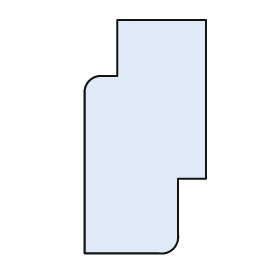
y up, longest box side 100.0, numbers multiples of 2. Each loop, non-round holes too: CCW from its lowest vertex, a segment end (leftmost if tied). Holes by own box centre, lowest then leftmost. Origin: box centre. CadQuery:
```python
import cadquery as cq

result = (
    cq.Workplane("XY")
    .moveTo(-26.0, -50.0)
    .lineTo(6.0, -50.0)
    .threePointArc((12.0, -48.0), (14.0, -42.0))
    .lineTo(14.0, -18.0)
    .lineTo(26.0, -18.0)
    .lineTo(26.0, 50.0)
    .lineTo(-12.0, 50.0)
    .lineTo(-12.0, 26.0)
    .lineTo(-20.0, 26.0)
    .threePointArc((-24.0, 24.0), (-26.0, 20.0))
    .close()
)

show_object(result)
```